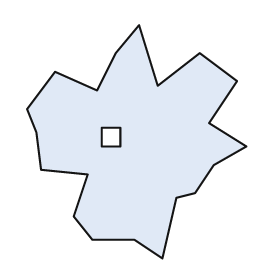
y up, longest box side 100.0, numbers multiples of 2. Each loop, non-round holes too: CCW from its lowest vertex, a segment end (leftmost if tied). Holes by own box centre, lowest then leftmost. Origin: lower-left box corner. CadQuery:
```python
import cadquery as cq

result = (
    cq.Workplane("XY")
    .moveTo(58.0, 0.0)
    .lineTo(64.0, 26.0)
    .lineTo(72.0, 28.0)
    .lineTo(80.0, 40.0)
    .lineTo(94.0, 48.0)
    .lineTo(78.0, 58.0)
    .lineTo(90.0, 76.0)
    .lineTo(74.0, 88.0)
    .lineTo(56.0, 74.0)
    .lineTo(48.0, 100.0)
    .lineTo(38.0, 88.0)
    .lineTo(30.0, 72.0)
    .lineTo(12.0, 80.0)
    .lineTo(0.0, 64.0)
    .lineTo(4.0, 54.0)
    .lineTo(6.0, 38.0)
    .lineTo(26.0, 36.0)
    .lineTo(20.0, 18.0)
    .lineTo(28.0, 8.0)
    .lineTo(46.0, 8.0)
    .close()
    .moveTo(32.0, 48.0)
    .lineTo(40.0, 48.0)
    .lineTo(40.0, 56.0)
    .lineTo(32.0, 56.0)
    .close()
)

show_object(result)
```